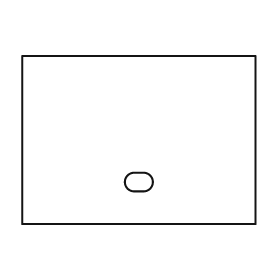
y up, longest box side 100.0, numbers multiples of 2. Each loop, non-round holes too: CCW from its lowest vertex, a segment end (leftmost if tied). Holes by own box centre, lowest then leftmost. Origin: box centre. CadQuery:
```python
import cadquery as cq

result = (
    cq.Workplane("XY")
    .moveTo(-50.0, -36.0)
    .lineTo(50.0, -36.0)
    .lineTo(50.0, 36.0)
    .lineTo(-50.0, 36.0)
    .close()
    .moveTo(-2.0, -22.0)
    .lineTo(2.0, -22.0)
    .threePointArc((6.0, -18.0), (2.0, -14.0))
    .lineTo(-2.0, -14.0)
    .threePointArc((-6.0, -18.0), (-2.0, -22.0))
    .close()
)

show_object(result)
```